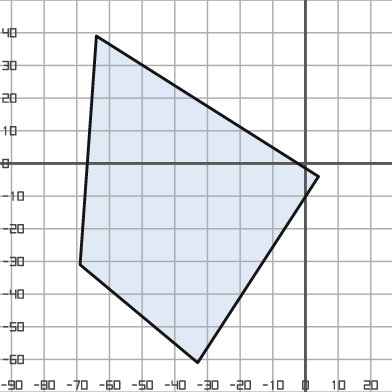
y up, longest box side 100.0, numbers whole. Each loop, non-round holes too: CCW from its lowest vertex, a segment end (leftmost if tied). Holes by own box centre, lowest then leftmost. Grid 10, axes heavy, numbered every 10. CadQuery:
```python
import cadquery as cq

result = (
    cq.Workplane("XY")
    .moveTo(-33.0, -61.0)
    .lineTo(4.0, -4.0)
    .lineTo(-64.0, 39.0)
    .lineTo(-69.0, -31.0)
    .close()
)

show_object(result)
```